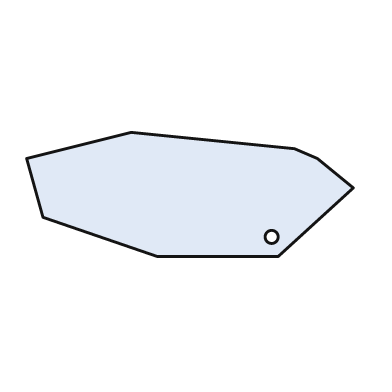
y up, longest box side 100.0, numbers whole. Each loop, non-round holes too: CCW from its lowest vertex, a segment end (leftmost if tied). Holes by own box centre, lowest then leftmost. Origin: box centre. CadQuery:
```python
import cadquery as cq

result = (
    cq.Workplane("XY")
    .moveTo(-10.0, -19.0)
    .lineTo(27.0, -19.0)
    .lineTo(50.0, 2.0)
    .lineTo(39.0, 11.0)
    .lineTo(32.0, 14.0)
    .lineTo(-18.0, 19.0)
    .lineTo(-50.0, 11.0)
    .lineTo(-45.0, -7.0)
    .close()
    .moveTo(25.0, -13.0)
    .circle(2.0)
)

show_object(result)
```